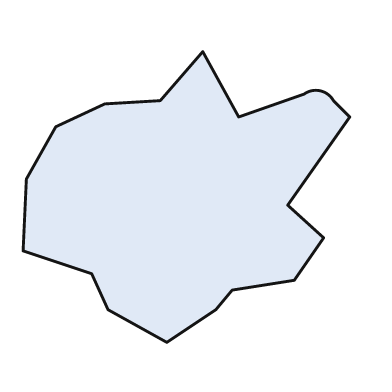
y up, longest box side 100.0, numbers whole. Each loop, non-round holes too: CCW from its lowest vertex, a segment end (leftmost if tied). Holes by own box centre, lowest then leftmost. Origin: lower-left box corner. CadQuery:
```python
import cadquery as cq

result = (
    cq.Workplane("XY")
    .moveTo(44.0, 0.0)
    .lineTo(59.0, 10.0)
    .lineTo(64.0, 16.0)
    .lineTo(83.0, 19.0)
    .lineTo(92.0, 32.0)
    .lineTo(81.0, 42.0)
    .lineTo(100.0, 69.0)
    .lineTo(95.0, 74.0)
    .threePointArc((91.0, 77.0), (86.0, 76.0))
    .lineTo(66.0, 69.0)
    .lineTo(55.0, 89.0)
    .lineTo(42.0, 74.0)
    .lineTo(25.0, 73.0)
    .lineTo(10.0, 66.0)
    .lineTo(1.0, 50.0)
    .lineTo(0.0, 28.0)
    .lineTo(21.0, 21.0)
    .lineTo(26.0, 10.0)
    .close()
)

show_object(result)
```